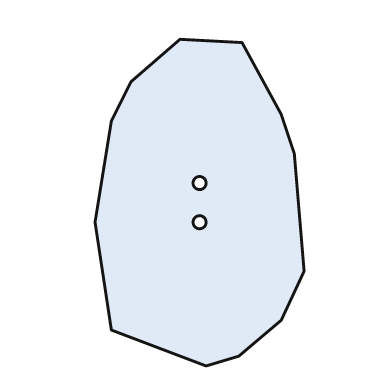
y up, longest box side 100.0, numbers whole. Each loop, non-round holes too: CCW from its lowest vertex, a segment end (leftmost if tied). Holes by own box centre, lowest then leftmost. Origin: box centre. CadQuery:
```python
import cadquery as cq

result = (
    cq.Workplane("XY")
    .moveTo(2.0, -50.0)
    .lineTo(12.0, -47.0)
    .lineTo(25.0, -36.0)
    .lineTo(32.0, -21.0)
    .lineTo(29.0, 15.0)
    .lineTo(25.0, 27.0)
    .lineTo(13.0, 49.0)
    .lineTo(-6.0, 50.0)
    .lineTo(-21.0, 37.0)
    .lineTo(-27.0, 25.0)
    .lineTo(-32.0, -6.0)
    .lineTo(-27.0, -39.0)
    .close()
    .moveTo(0.0, -6.0)
    .circle(2.0)
    .moveTo(0.0, 6.0)
    .circle(2.0)
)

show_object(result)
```